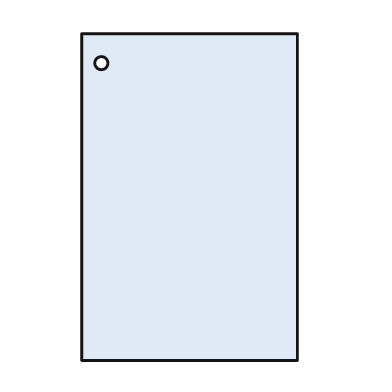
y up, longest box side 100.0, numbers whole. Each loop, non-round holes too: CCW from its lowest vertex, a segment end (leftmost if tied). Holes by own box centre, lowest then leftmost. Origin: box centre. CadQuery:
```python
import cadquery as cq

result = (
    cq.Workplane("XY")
    .moveTo(-33.0, -50.0)
    .lineTo(33.0, -50.0)
    .lineTo(33.0, 50.0)
    .lineTo(-33.0, 50.0)
    .close()
    .moveTo(-27.0, 41.0)
    .circle(2.0)
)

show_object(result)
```